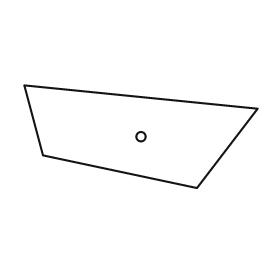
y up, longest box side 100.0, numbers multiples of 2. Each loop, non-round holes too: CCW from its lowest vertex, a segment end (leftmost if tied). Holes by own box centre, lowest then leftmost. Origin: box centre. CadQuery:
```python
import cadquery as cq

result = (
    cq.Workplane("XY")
    .moveTo(24.0, -22.0)
    .lineTo(50.0, 12.0)
    .lineTo(-50.0, 22.0)
    .lineTo(-42.0, -8.0)
    .close()
    .moveTo(0.0, 0.0)
    .circle(2.0)
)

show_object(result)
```